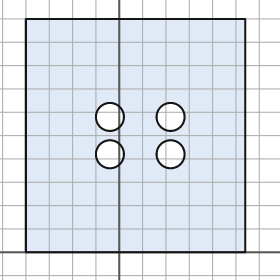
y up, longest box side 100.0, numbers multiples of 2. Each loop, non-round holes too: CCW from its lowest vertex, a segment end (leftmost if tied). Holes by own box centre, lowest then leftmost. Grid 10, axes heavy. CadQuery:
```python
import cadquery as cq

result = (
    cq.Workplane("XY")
    .moveTo(-40.0, 0.0)
    .lineTo(54.0, 0.0)
    .lineTo(54.0, 100.0)
    .lineTo(-40.0, 100.0)
    .close()
    .moveTo(-4.0, 42.0)
    .circle(6.0)
    .moveTo(22.0, 42.0)
    .circle(6.0)
    .moveTo(-4.0, 58.0)
    .circle(6.0)
    .moveTo(22.0, 58.0)
    .circle(6.0)
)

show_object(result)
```